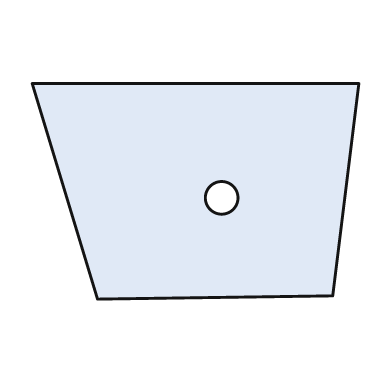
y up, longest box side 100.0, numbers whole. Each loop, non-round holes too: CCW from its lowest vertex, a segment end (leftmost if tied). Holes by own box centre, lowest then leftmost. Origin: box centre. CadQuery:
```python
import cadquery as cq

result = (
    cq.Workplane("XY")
    .moveTo(-30.0, -33.0)
    .lineTo(42.0, -32.0)
    .lineTo(50.0, 33.0)
    .lineTo(-50.0, 33.0)
    .close()
    .moveTo(8.0, -2.0)
    .circle(5.0)
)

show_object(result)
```